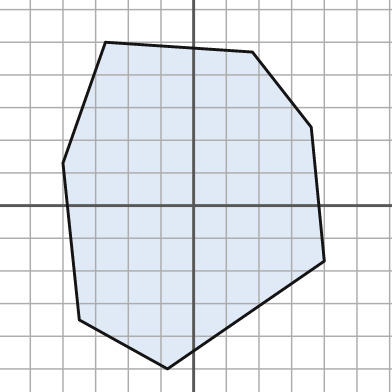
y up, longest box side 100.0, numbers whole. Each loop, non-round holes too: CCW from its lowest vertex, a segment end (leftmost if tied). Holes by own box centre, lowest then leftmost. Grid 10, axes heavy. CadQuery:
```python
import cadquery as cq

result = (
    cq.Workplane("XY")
    .moveTo(-8.0, -50.0)
    .lineTo(40.0, -17.0)
    .lineTo(36.0, 24.0)
    .lineTo(18.0, 47.0)
    .lineTo(-27.0, 50.0)
    .lineTo(-40.0, 13.0)
    .lineTo(-35.0, -35.0)
    .close()
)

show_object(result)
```